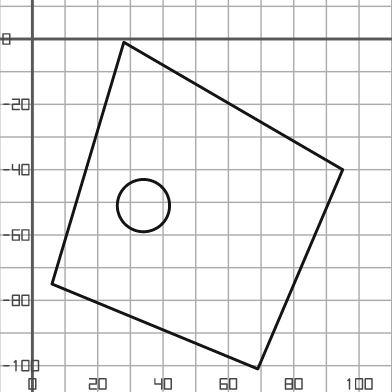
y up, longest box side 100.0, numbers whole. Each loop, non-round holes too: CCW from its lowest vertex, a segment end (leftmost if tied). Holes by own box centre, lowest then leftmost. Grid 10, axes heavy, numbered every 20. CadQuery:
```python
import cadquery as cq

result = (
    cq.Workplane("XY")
    .moveTo(69.0, -101.0)
    .lineTo(95.0, -40.0)
    .lineTo(28.0, -1.0)
    .lineTo(6.0, -75.0)
    .close()
    .moveTo(34.0, -51.0)
    .circle(8.0)
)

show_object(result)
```